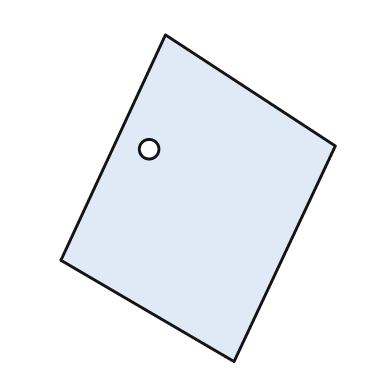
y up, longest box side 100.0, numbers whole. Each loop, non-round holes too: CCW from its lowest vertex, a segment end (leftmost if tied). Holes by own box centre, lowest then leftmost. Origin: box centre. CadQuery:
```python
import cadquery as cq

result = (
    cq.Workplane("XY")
    .moveTo(11.0, -50.0)
    .lineTo(42.0, 16.0)
    .lineTo(-10.0, 50.0)
    .lineTo(-42.0, -19.0)
    .close()
    .moveTo(-15.0, 15.0)
    .circle(3.0)
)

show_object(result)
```